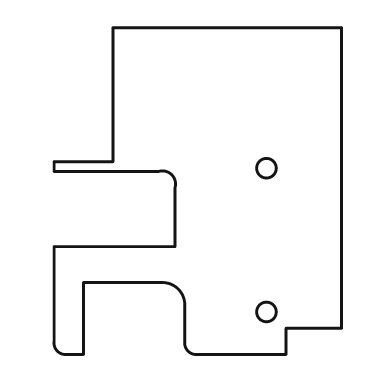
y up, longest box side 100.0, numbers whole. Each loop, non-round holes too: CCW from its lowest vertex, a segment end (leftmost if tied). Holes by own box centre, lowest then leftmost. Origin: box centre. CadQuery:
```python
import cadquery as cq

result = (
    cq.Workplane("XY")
    .moveTo(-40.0, -50.0)
    .lineTo(-35.0, -50.0)
    .lineTo(-35.0, -28.0)
    .lineTo(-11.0, -28.0)
    .threePointArc((-6.0, -30.0), (-4.0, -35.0))
    .lineTo(-4.0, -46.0)
    .threePointArc((-3.0, -49.0), (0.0, -50.0))
    .lineTo(27.0, -50.0)
    .lineTo(27.0, -42.0)
    .lineTo(44.0, -42.0)
    .lineTo(44.0, 50.0)
    .lineTo(-26.0, 50.0)
    .lineTo(-26.0, 9.0)
    .lineTo(-44.0, 9.0)
    .lineTo(-44.0, 6.0)
    .lineTo(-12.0, 6.0)
    .threePointArc((-8.0, 5.0), (-7.0, 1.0))
    .lineTo(-7.0, -17.0)
    .lineTo(-44.0, -17.0)
    .lineTo(-44.0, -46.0)
    .threePointArc((-43.0, -49.0), (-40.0, -50.0))
    .close()
    .moveTo(21.0, -37.0)
    .circle(3.0)
    .moveTo(21.0, 7.0)
    .circle(3.0)
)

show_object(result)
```